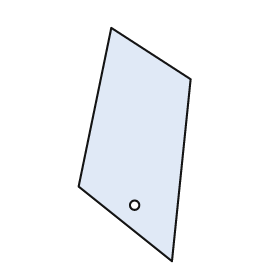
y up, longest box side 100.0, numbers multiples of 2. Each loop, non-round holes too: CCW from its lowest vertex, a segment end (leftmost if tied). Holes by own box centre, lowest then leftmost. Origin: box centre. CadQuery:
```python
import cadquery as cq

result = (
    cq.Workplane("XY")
    .moveTo(16.0, -50.0)
    .lineTo(24.0, 28.0)
    .lineTo(-10.0, 50.0)
    .lineTo(-24.0, -18.0)
    .close()
    .moveTo(0.0, -26.0)
    .circle(2.0)
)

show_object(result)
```